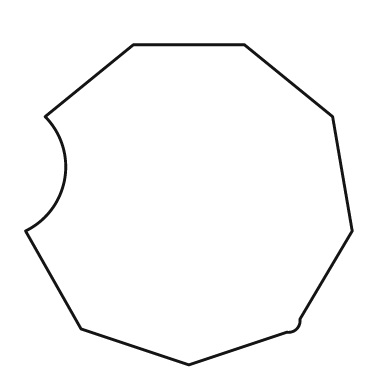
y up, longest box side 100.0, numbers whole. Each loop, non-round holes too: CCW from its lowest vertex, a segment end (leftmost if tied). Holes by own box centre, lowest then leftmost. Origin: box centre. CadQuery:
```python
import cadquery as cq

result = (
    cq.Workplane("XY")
    .moveTo(0.0, -49.0)
    .lineTo(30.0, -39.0)
    .threePointArc((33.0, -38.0), (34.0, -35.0))
    .lineTo(50.0, -8.0)
    .lineTo(44.0, 27.0)
    .lineTo(17.0, 49.0)
    .lineTo(-17.0, 49.0)
    .lineTo(-44.0, 27.0)
    .threePointArc((-38.0, 8.0), (-50.0, -8.0))
    .lineTo(-33.0, -38.0)
    .close()
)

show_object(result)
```